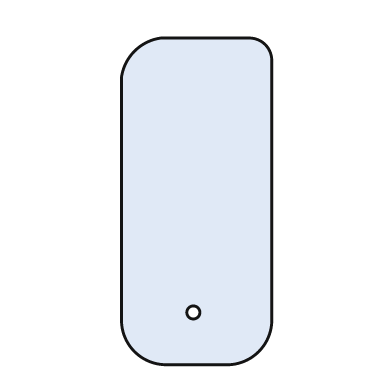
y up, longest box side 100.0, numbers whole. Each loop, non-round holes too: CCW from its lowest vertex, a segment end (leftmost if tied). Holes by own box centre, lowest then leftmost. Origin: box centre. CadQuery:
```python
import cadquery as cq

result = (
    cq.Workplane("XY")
    .moveTo(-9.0, -50.0)
    .lineTo(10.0, -50.0)
    .threePointArc((19.0, -46.0), (23.0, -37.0))
    .lineTo(23.0, 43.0)
    .threePointArc((21.0, 48.0), (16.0, 50.0))
    .lineTo(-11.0, 50.0)
    .threePointArc((-19.0, 46.0), (-23.0, 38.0))
    .lineTo(-23.0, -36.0)
    .threePointArc((-19.0, -46.0), (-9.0, -50.0))
    .close()
    .moveTo(-1.0, -34.0)
    .circle(2.0)
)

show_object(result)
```